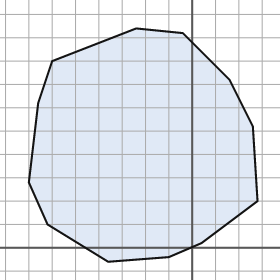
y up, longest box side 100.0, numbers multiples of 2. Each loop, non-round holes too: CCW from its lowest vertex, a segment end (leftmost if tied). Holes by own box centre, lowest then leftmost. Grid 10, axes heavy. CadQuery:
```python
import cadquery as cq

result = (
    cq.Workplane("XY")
    .moveTo(-36.0, -6.0)
    .lineTo(-10.0, -4.0)
    .lineTo(4.0, 2.0)
    .lineTo(28.0, 20.0)
    .lineTo(26.0, 52.0)
    .lineTo(16.0, 72.0)
    .lineTo(-4.0, 92.0)
    .lineTo(-24.0, 94.0)
    .lineTo(-60.0, 80.0)
    .lineTo(-66.0, 62.0)
    .lineTo(-70.0, 28.0)
    .lineTo(-62.0, 10.0)
    .close()
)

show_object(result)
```